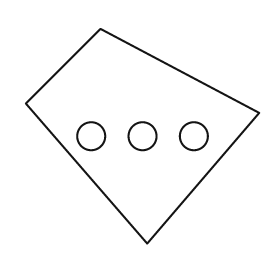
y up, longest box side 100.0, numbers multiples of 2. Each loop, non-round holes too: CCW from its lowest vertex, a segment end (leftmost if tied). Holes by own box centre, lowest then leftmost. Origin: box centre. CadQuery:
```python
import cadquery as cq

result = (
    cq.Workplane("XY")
    .moveTo(2.0, -46.0)
    .lineTo(50.0, 10.0)
    .lineTo(-18.0, 46.0)
    .lineTo(-50.0, 14.0)
    .close()
    .moveTo(-22.0, 0.0)
    .circle(6.0)
    .moveTo(0.0, 0.0)
    .circle(6.0)
    .moveTo(22.0, 0.0)
    .circle(6.0)
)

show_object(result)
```